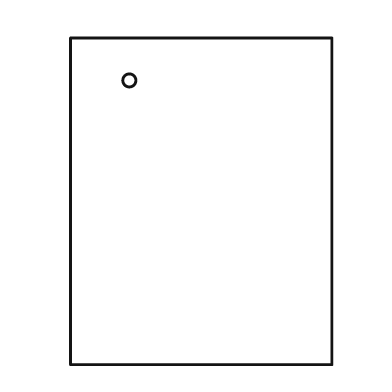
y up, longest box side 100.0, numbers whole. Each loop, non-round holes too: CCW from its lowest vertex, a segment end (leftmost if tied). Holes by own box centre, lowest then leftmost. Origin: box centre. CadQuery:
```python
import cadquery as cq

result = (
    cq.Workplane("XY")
    .moveTo(-40.0, -50.0)
    .lineTo(40.0, -50.0)
    .lineTo(40.0, 50.0)
    .lineTo(-40.0, 50.0)
    .close()
    .moveTo(-22.0, 37.0)
    .circle(2.0)
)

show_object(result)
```